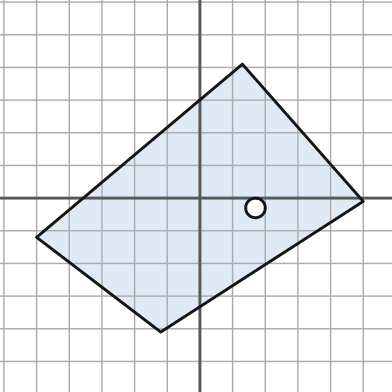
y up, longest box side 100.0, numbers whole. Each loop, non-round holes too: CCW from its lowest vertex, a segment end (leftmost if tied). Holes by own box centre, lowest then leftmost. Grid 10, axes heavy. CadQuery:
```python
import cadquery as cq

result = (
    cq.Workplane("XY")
    .moveTo(-12.0, -41.0)
    .lineTo(50.0, -1.0)
    .lineTo(13.0, 41.0)
    .lineTo(-50.0, -12.0)
    .close()
    .moveTo(17.0, -3.0)
    .circle(3.0)
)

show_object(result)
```